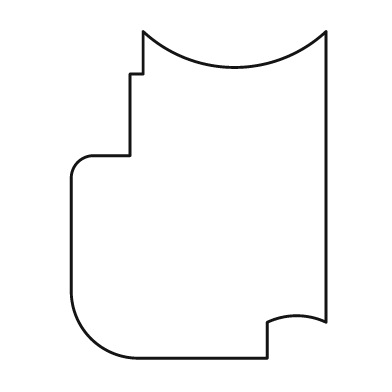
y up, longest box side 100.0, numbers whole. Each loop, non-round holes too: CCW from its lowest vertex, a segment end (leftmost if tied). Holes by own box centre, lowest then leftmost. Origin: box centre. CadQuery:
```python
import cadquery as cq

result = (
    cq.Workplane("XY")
    .moveTo(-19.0, -50.0)
    .lineTo(21.0, -50.0)
    .lineTo(21.0, -39.0)
    .threePointArc((30.0, -37.0), (39.0, -39.0))
    .lineTo(39.0, 50.0)
    .threePointArc((11.0, 39.0), (-17.0, 50.0))
    .lineTo(-17.0, 37.0)
    .lineTo(-21.0, 37.0)
    .lineTo(-21.0, 12.0)
    .lineTo(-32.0, 12.0)
    .threePointArc((-37.0, 10.0), (-39.0, 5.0))
    .lineTo(-39.0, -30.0)
    .threePointArc((-33.0, -44.0), (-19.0, -50.0))
    .close()
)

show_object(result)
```